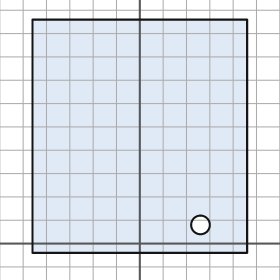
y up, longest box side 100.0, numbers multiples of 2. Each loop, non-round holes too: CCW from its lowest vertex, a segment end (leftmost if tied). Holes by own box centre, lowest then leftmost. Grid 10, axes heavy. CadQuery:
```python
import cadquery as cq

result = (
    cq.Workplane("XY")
    .moveTo(-46.0, -4.0)
    .lineTo(46.0, -4.0)
    .lineTo(46.0, 96.0)
    .lineTo(-46.0, 96.0)
    .close()
    .moveTo(26.0, 8.0)
    .circle(4.0)
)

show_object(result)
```